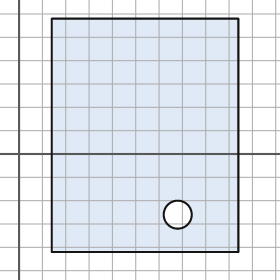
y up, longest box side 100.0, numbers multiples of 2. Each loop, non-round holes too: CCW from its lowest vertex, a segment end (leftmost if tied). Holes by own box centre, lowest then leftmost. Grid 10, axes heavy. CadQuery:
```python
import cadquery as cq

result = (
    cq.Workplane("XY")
    .moveTo(14.0, -42.0)
    .lineTo(94.0, -42.0)
    .lineTo(94.0, 58.0)
    .lineTo(14.0, 58.0)
    .close()
    .moveTo(68.0, -26.0)
    .circle(6.0)
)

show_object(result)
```